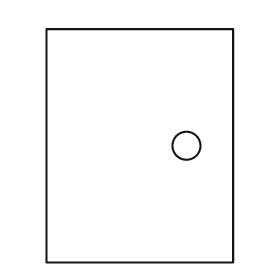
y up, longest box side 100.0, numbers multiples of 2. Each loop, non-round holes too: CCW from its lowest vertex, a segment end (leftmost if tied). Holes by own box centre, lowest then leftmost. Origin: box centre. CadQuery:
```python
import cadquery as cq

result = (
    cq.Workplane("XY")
    .moveTo(-40.0, -50.0)
    .lineTo(40.0, -50.0)
    .lineTo(40.0, 50.0)
    .lineTo(-40.0, 50.0)
    .close()
    .moveTo(20.0, 0.0)
    .circle(6.0)
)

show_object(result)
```